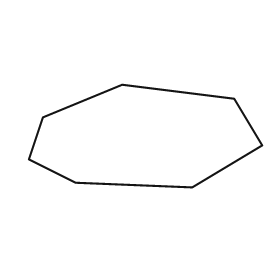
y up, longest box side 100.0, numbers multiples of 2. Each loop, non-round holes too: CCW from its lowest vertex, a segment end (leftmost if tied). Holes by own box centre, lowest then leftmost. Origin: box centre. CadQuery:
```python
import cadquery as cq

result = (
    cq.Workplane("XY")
    .moveTo(20.0, -22.0)
    .lineTo(50.0, -4.0)
    .lineTo(38.0, 16.0)
    .lineTo(-10.0, 22.0)
    .lineTo(-44.0, 8.0)
    .lineTo(-50.0, -10.0)
    .lineTo(-30.0, -20.0)
    .close()
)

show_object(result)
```